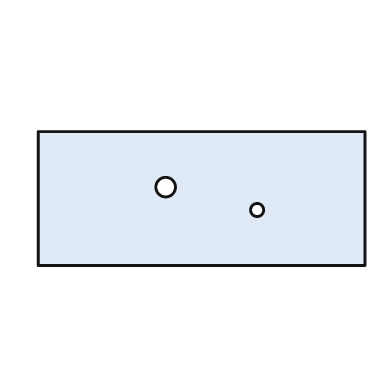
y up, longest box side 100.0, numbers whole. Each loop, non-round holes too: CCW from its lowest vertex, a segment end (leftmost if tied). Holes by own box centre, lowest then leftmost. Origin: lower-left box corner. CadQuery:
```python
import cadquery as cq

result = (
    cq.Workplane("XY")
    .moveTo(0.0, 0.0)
    .lineTo(100.0, 0.0)
    .lineTo(100.0, 41.0)
    .lineTo(0.0, 41.0)
    .close()
    .moveTo(67.0, 17.0)
    .circle(2.0)
    .moveTo(39.0, 24.0)
    .circle(3.0)
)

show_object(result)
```